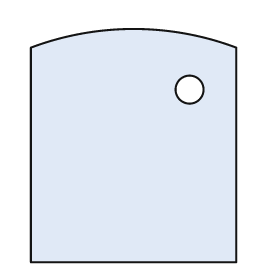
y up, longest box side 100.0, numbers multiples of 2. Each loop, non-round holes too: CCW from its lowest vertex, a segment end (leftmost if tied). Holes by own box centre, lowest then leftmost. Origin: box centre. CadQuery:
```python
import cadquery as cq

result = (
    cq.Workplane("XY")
    .moveTo(-44.0, -50.0)
    .lineTo(44.0, -50.0)
    .lineTo(44.0, 42.0)
    .threePointArc((0.0, 50.0), (-44.0, 42.0))
    .close()
    .moveTo(24.0, 24.0)
    .circle(6.0)
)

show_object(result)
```